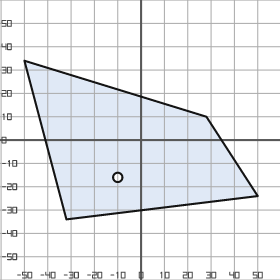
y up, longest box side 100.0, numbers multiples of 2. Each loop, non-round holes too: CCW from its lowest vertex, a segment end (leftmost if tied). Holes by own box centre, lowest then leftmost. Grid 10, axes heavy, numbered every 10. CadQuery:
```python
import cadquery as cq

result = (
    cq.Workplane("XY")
    .moveTo(-32.0, -34.0)
    .lineTo(50.0, -24.0)
    .lineTo(28.0, 10.0)
    .lineTo(-50.0, 34.0)
    .close()
    .moveTo(-10.0, -16.0)
    .circle(2.0)
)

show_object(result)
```